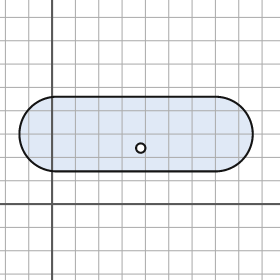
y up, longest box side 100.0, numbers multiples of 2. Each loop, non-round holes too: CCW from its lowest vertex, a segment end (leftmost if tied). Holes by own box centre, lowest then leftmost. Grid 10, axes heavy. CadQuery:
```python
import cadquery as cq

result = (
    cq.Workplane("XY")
    .moveTo(2.0, 14.0)
    .lineTo(70.0, 14.0)
    .threePointArc((86.0, 30.0), (70.0, 46.0))
    .lineTo(2.0, 46.0)
    .threePointArc((-14.0, 30.0), (2.0, 14.0))
    .close()
    .moveTo(38.0, 24.0)
    .circle(2.0)
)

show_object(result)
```